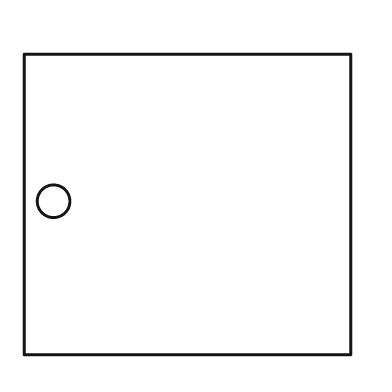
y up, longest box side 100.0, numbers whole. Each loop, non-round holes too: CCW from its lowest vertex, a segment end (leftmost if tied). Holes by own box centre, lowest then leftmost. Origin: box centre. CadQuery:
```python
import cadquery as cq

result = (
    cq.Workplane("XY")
    .moveTo(-50.0, -46.0)
    .lineTo(50.0, -46.0)
    .lineTo(50.0, 46.0)
    .lineTo(-50.0, 46.0)
    .close()
    .moveTo(-41.0, 1.0)
    .circle(5.0)
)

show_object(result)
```